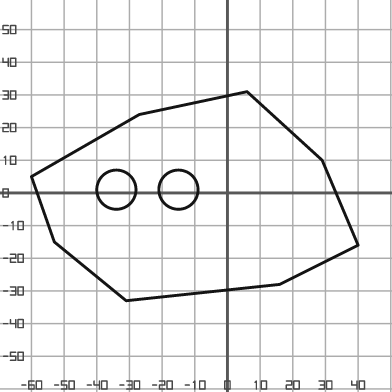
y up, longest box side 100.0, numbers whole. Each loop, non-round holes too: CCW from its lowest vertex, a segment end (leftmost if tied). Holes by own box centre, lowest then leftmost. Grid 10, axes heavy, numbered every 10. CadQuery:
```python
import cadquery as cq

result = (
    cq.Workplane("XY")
    .moveTo(-31.0, -33.0)
    .lineTo(16.0, -28.0)
    .lineTo(40.0, -16.0)
    .lineTo(29.0, 10.0)
    .lineTo(6.0, 31.0)
    .lineTo(-27.0, 24.0)
    .lineTo(-60.0, 5.0)
    .lineTo(-53.0, -15.0)
    .close()
    .moveTo(-34.0, 1.0)
    .circle(6.0)
    .moveTo(-15.0, 1.0)
    .circle(6.0)
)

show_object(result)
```